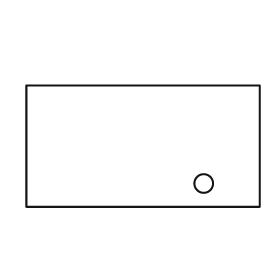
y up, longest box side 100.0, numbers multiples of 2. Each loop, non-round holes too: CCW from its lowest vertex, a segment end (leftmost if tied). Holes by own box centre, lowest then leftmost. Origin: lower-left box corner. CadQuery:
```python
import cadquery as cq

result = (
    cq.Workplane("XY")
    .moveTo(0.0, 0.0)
    .lineTo(100.0, 0.0)
    .lineTo(100.0, 52.0)
    .lineTo(0.0, 52.0)
    .close()
    .moveTo(76.0, 10.0)
    .circle(4.0)
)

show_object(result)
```